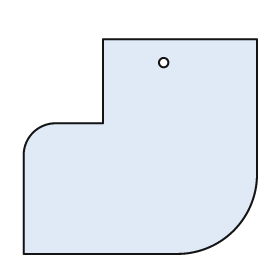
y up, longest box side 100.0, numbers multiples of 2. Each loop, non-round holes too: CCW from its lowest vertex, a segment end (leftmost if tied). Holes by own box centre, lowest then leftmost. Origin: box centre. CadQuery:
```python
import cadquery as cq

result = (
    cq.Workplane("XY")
    .moveTo(-50.0, -46.0)
    .lineTo(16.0, -46.0)
    .threePointArc((40.0, -36.0), (50.0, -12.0))
    .lineTo(50.0, 46.0)
    .lineTo(-16.0, 46.0)
    .lineTo(-16.0, 10.0)
    .lineTo(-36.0, 10.0)
    .threePointArc((-46.0, 6.0), (-50.0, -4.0))
    .close()
    .moveTo(10.0, 36.0)
    .circle(2.0)
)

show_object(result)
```